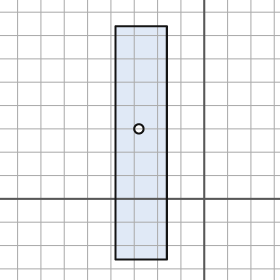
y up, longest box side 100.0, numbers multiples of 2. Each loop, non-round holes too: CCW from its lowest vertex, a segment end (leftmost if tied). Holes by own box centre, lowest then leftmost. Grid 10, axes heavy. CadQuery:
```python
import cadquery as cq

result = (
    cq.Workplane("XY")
    .moveTo(-38.0, -26.0)
    .lineTo(-16.0, -26.0)
    .lineTo(-16.0, 74.0)
    .lineTo(-38.0, 74.0)
    .close()
    .moveTo(-28.0, 30.0)
    .circle(2.0)
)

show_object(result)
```